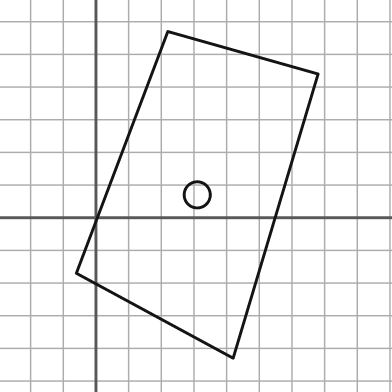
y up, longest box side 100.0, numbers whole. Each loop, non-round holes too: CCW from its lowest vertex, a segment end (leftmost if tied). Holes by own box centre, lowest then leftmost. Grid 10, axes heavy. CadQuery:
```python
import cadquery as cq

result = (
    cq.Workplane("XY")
    .moveTo(42.0, -43.0)
    .lineTo(68.0, 44.0)
    .lineTo(22.0, 57.0)
    .lineTo(-6.0, -17.0)
    .close()
    .moveTo(31.0, 7.0)
    .circle(4.0)
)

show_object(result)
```